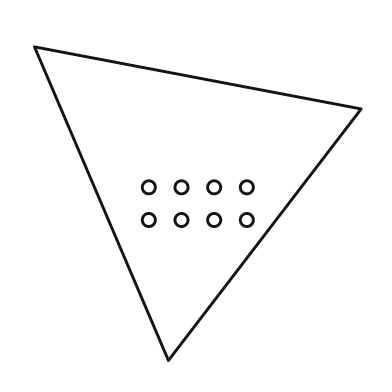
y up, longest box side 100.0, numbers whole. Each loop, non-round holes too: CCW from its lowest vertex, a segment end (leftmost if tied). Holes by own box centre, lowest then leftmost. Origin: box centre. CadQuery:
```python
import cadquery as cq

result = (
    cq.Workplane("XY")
    .moveTo(-9.0, -48.0)
    .lineTo(50.0, 29.0)
    .lineTo(-50.0, 48.0)
    .close()
    .moveTo(-15.0, -5.0)
    .circle(2.0)
    .moveTo(-5.0, -5.0)
    .circle(2.0)
    .moveTo(5.0, -5.0)
    .circle(2.0)
    .moveTo(15.0, -5.0)
    .circle(2.0)
    .moveTo(-15.0, 5.0)
    .circle(2.0)
    .moveTo(-5.0, 5.0)
    .circle(2.0)
    .moveTo(5.0, 5.0)
    .circle(2.0)
    .moveTo(15.0, 5.0)
    .circle(2.0)
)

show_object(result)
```